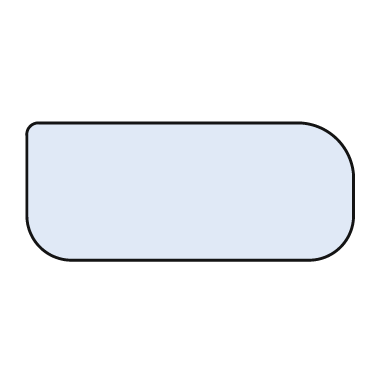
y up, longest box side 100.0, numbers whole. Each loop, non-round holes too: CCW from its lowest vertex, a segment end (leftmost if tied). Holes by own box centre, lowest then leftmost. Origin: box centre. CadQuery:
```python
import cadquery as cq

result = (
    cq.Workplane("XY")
    .moveTo(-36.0, -21.0)
    .lineTo(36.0, -21.0)
    .threePointArc((46.0, -17.0), (50.0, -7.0))
    .lineTo(50.0, 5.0)
    .threePointArc((45.0, 16.0), (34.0, 21.0))
    .lineTo(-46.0, 21.0)
    .threePointArc((-49.0, 20.0), (-50.0, 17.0))
    .lineTo(-50.0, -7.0)
    .threePointArc((-46.0, -17.0), (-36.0, -21.0))
    .close()
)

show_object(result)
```